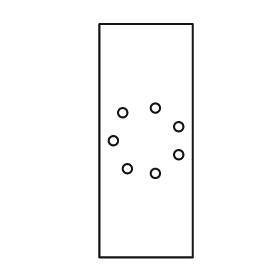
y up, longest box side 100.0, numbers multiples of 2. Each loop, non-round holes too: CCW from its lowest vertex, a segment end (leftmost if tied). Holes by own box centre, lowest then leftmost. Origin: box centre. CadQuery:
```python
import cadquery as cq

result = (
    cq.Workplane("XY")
    .moveTo(-20.0, -50.0)
    .lineTo(20.0, -50.0)
    .lineTo(20.0, 50.0)
    .lineTo(-20.0, 50.0)
    .close()
    .moveTo(4.0, -14.0)
    .circle(2.0)
    .moveTo(-8.0, -12.0)
    .circle(2.0)
    .moveTo(14.0, -6.0)
    .circle(2.0)
    .moveTo(-14.0, 0.0)
    .circle(2.0)
    .moveTo(14.0, 6.0)
    .circle(2.0)
    .moveTo(-10.0, 12.0)
    .circle(2.0)
    .moveTo(4.0, 14.0)
    .circle(2.0)
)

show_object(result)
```